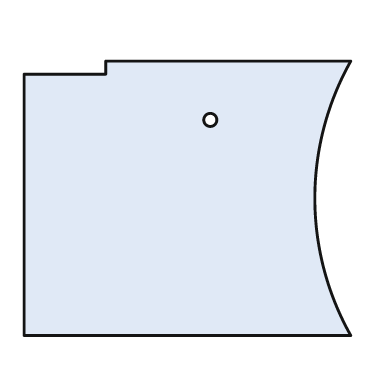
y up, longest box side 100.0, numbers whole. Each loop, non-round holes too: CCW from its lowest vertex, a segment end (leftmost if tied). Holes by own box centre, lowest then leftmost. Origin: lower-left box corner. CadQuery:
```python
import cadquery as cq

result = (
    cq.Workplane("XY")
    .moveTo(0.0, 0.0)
    .lineTo(100.0, 0.0)
    .threePointArc((89.0, 42.0), (100.0, 84.0))
    .lineTo(25.0, 84.0)
    .lineTo(25.0, 80.0)
    .lineTo(0.0, 80.0)
    .close()
    .moveTo(57.0, 66.0)
    .circle(2.0)
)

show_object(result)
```